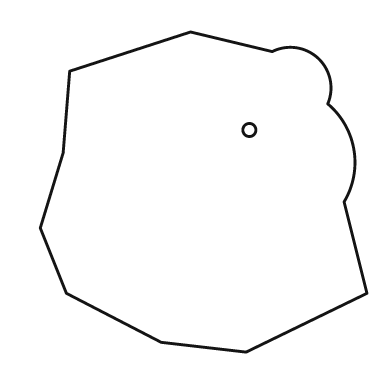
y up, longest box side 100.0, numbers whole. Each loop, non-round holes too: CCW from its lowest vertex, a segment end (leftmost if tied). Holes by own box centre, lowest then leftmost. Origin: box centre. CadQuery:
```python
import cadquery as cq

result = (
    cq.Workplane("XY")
    .moveTo(13.0, -49.0)
    .lineTo(50.0, -31.0)
    .lineTo(43.0, -3.0)
    .threePointArc((46.0, 13.0), (38.0, 27.0))
    .threePointArc((35.0, 41.0), (21.0, 43.0))
    .lineTo(-4.0, 49.0)
    .lineTo(-41.0, 37.0)
    .lineTo(-43.0, 12.0)
    .lineTo(-50.0, -11.0)
    .lineTo(-42.0, -31.0)
    .lineTo(-13.0, -46.0)
    .close()
    .moveTo(14.0, 19.0)
    .circle(2.0)
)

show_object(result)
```